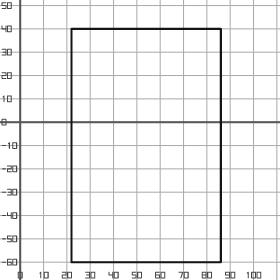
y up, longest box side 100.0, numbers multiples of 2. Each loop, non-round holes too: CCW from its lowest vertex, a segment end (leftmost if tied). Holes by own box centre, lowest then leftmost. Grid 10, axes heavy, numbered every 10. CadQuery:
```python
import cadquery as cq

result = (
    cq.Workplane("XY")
    .moveTo(22.0, -60.0)
    .lineTo(86.0, -60.0)
    .lineTo(86.0, 40.0)
    .lineTo(22.0, 40.0)
    .close()
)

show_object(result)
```